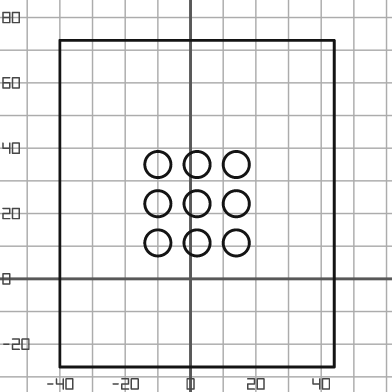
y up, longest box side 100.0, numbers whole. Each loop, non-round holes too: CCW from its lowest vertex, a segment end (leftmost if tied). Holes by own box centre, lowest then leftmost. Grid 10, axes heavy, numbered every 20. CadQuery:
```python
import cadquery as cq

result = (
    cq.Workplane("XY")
    .moveTo(-40.0, -27.0)
    .lineTo(44.0, -27.0)
    .lineTo(44.0, 73.0)
    .lineTo(-40.0, 73.0)
    .close()
    .moveTo(-10.0, 11.0)
    .circle(4.0)
    .moveTo(2.0, 11.0)
    .circle(4.0)
    .moveTo(14.0, 11.0)
    .circle(4.0)
    .moveTo(-10.0, 23.0)
    .circle(4.0)
    .moveTo(2.0, 23.0)
    .circle(4.0)
    .moveTo(14.0, 23.0)
    .circle(4.0)
    .moveTo(-10.0, 35.0)
    .circle(4.0)
    .moveTo(2.0, 35.0)
    .circle(4.0)
    .moveTo(14.0, 35.0)
    .circle(4.0)
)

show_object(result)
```